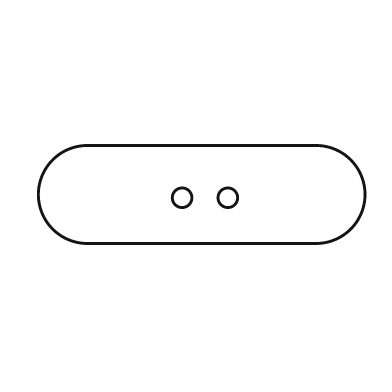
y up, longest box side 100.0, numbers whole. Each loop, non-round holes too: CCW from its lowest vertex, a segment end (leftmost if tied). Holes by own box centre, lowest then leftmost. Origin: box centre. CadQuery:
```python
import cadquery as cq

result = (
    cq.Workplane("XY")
    .moveTo(-35.0, -15.0)
    .lineTo(35.0, -15.0)
    .threePointArc((50.0, 0.0), (35.0, 15.0))
    .lineTo(-35.0, 15.0)
    .threePointArc((-50.0, 0.0), (-35.0, -15.0))
    .close()
    .moveTo(-6.0, -1.0)
    .circle(3.0)
    .moveTo(8.0, -1.0)
    .circle(3.0)
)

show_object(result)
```